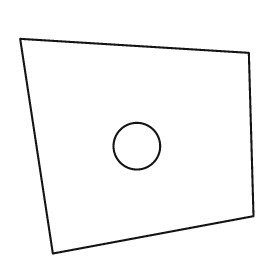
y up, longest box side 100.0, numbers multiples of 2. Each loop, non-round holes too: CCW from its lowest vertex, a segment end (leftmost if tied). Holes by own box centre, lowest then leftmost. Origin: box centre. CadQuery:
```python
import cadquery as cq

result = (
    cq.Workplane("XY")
    .moveTo(-36.0, -46.0)
    .lineTo(50.0, -30.0)
    .lineTo(48.0, 40.0)
    .lineTo(-50.0, 46.0)
    .close()
    .moveTo(0.0, 0.0)
    .circle(10.0)
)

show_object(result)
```